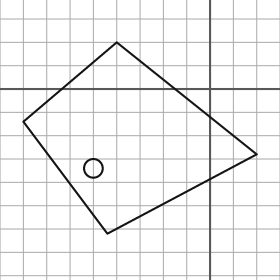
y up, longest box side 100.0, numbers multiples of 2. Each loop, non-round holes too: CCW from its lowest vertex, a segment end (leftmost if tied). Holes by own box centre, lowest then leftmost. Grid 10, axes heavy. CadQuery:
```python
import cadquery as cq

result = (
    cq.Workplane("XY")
    .moveTo(-44.0, -62.0)
    .lineTo(20.0, -28.0)
    .lineTo(-40.0, 20.0)
    .lineTo(-80.0, -14.0)
    .close()
    .moveTo(-50.0, -34.0)
    .circle(4.0)
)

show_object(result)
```